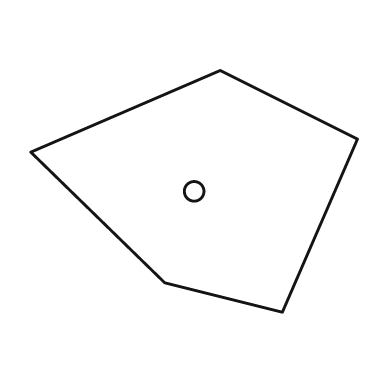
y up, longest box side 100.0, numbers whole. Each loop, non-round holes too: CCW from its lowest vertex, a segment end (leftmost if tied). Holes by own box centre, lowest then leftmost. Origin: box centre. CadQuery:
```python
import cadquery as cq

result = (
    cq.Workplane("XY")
    .moveTo(27.0, -37.0)
    .lineTo(50.0, 16.0)
    .lineTo(8.0, 37.0)
    .lineTo(-50.0, 12.0)
    .lineTo(-9.0, -28.0)
    .close()
    .moveTo(0.0, 0.0)
    .circle(3.0)
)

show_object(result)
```